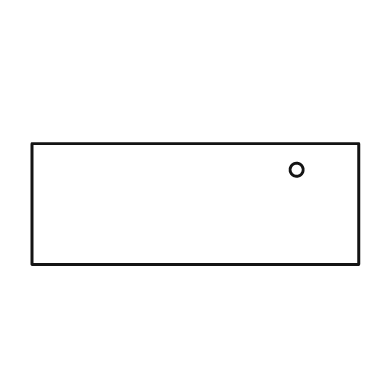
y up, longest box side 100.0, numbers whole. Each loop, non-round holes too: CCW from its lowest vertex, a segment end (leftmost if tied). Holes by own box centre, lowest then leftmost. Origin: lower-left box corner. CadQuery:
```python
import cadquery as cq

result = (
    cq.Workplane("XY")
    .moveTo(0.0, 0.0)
    .lineTo(100.0, 0.0)
    .lineTo(100.0, 37.0)
    .lineTo(0.0, 37.0)
    .close()
    .moveTo(81.0, 29.0)
    .circle(2.0)
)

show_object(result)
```